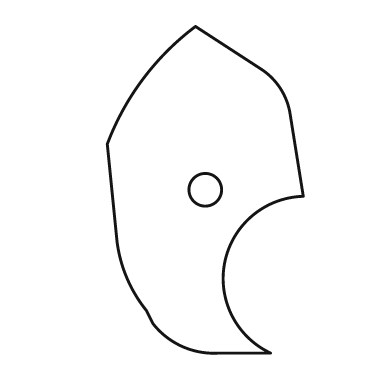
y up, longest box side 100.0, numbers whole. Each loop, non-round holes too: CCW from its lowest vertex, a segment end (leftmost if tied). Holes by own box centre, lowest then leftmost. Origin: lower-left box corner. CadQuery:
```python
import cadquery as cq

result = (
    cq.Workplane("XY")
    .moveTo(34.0, 0.0)
    .lineTo(50.0, 0.0)
    .threePointArc((36.0, 28.0), (60.0, 48.0))
    .lineTo(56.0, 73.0)
    .threePointArc((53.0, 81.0), (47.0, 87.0))
    .lineTo(27.0, 100.0)
    .threePointArc((11.0, 84.0), (0.0, 64.0))
    .lineTo(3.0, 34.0)
    .threePointArc((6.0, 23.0), (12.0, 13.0))
    .lineTo(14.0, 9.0)
    .threePointArc((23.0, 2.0), (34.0, 0.0))
    .close()
    .moveTo(30.0, 50.0)
    .circle(5.0)
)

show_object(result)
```